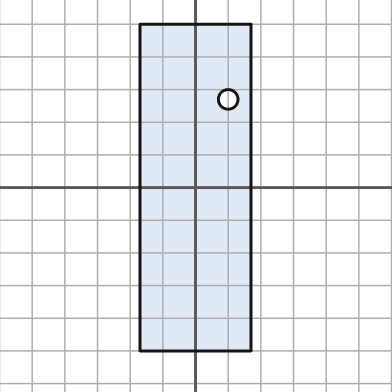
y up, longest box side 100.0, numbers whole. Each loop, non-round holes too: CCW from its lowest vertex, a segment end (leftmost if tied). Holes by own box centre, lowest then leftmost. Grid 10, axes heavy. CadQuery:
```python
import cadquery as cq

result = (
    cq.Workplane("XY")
    .moveTo(-17.0, -50.0)
    .lineTo(17.0, -50.0)
    .lineTo(17.0, 50.0)
    .lineTo(-17.0, 50.0)
    .close()
    .moveTo(10.0, 27.0)
    .circle(3.0)
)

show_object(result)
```